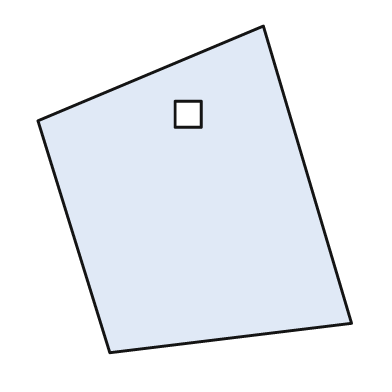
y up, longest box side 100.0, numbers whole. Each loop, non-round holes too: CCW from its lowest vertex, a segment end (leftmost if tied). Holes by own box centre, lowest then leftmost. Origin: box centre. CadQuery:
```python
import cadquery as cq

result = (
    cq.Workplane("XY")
    .moveTo(-26.0, -50.0)
    .lineTo(48.0, -41.0)
    .lineTo(21.0, 50.0)
    .lineTo(-48.0, 21.0)
    .close()
    .moveTo(-6.0, 19.0)
    .lineTo(2.0, 19.0)
    .lineTo(2.0, 27.0)
    .lineTo(-6.0, 27.0)
    .close()
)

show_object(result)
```